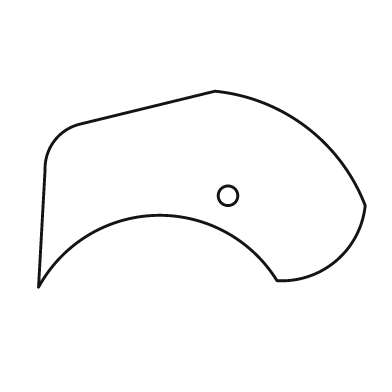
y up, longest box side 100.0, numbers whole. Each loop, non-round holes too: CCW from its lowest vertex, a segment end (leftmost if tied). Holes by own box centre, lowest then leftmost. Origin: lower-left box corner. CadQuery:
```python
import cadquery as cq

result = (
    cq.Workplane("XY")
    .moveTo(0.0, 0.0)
    .threePointArc((36.0, 22.0), (73.0, 2.0))
    .threePointArc((91.0, 8.0), (100.0, 25.0))
    .threePointArc((82.0, 49.0), (54.0, 60.0))
    .lineTo(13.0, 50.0)
    .threePointArc((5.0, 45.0), (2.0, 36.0))
    .close()
    .moveTo(58.0, 28.0)
    .circle(3.0)
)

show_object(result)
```